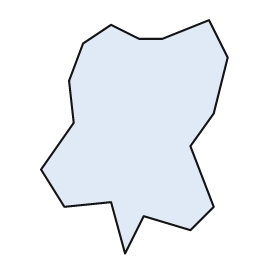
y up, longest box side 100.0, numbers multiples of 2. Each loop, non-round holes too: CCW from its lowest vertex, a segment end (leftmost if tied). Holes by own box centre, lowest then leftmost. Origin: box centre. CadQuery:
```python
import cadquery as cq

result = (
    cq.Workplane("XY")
    .moveTo(-4.0, -50.0)
    .lineTo(4.0, -34.0)
    .lineTo(24.0, -40.0)
    .lineTo(34.0, -30.0)
    .lineTo(24.0, -4.0)
    .lineTo(34.0, 10.0)
    .lineTo(40.0, 34.0)
    .lineTo(32.0, 50.0)
    .lineTo(12.0, 42.0)
    .lineTo(2.0, 42.0)
    .lineTo(-10.0, 48.0)
    .lineTo(-22.0, 40.0)
    .lineTo(-28.0, 24.0)
    .lineTo(-26.0, 6.0)
    .lineTo(-40.0, -14.0)
    .lineTo(-30.0, -30.0)
    .lineTo(-10.0, -28.0)
    .close()
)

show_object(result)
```